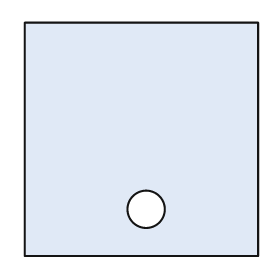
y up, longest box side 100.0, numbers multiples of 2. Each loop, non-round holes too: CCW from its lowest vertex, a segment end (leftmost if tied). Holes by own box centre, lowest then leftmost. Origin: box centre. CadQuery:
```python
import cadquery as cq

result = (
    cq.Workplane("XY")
    .moveTo(-50.0, -50.0)
    .lineTo(50.0, -50.0)
    .lineTo(50.0, 50.0)
    .lineTo(-50.0, 50.0)
    .close()
    .moveTo(2.0, -30.0)
    .circle(8.0)
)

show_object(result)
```